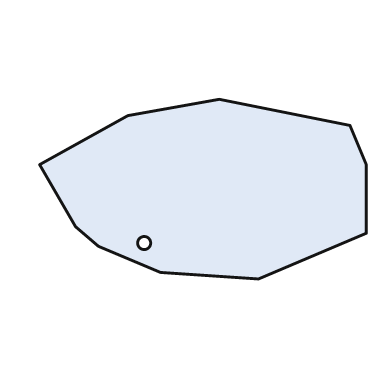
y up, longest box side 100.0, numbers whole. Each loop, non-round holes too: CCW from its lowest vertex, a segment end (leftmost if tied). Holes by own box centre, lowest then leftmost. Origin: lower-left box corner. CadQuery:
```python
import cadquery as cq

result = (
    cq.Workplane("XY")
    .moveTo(67.0, 0.0)
    .lineTo(100.0, 14.0)
    .lineTo(100.0, 35.0)
    .lineTo(95.0, 47.0)
    .lineTo(55.0, 55.0)
    .lineTo(27.0, 50.0)
    .lineTo(0.0, 35.0)
    .lineTo(11.0, 16.0)
    .lineTo(18.0, 10.0)
    .lineTo(37.0, 2.0)
    .close()
    .moveTo(32.0, 11.0)
    .circle(2.0)
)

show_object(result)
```